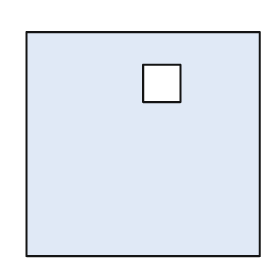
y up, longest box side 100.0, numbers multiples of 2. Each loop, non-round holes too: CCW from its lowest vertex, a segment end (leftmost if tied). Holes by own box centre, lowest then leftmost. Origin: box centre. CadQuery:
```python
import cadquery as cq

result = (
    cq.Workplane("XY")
    .moveTo(-50.0, -48.0)
    .lineTo(50.0, -48.0)
    .lineTo(50.0, 48.0)
    .lineTo(-50.0, 48.0)
    .close()
    .moveTo(0.0, 18.0)
    .lineTo(16.0, 18.0)
    .lineTo(16.0, 34.0)
    .lineTo(0.0, 34.0)
    .close()
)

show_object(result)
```